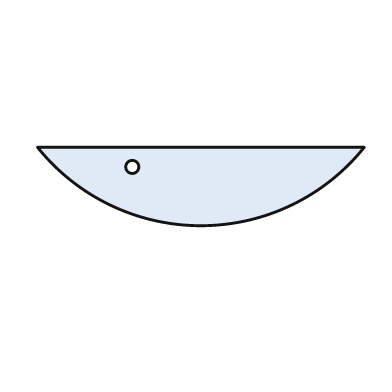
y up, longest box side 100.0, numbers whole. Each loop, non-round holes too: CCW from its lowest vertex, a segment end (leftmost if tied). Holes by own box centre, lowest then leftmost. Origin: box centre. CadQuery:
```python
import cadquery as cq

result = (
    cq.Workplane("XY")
    .moveTo(-50.0, 12.0)
    .threePointArc((0.0, -12.0), (50.0, 12.0))
    .close()
    .moveTo(-21.0, 6.0)
    .circle(2.0)
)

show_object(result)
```